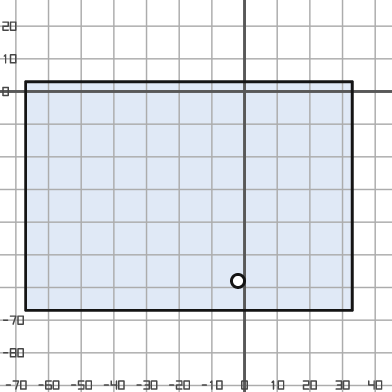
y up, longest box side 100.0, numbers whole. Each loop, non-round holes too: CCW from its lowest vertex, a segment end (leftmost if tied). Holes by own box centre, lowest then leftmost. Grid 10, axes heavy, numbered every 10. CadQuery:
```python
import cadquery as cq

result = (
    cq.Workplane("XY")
    .moveTo(-67.0, -67.0)
    .lineTo(33.0, -67.0)
    .lineTo(33.0, 3.0)
    .lineTo(-67.0, 3.0)
    .close()
    .moveTo(-2.0, -58.0)
    .circle(2.0)
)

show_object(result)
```